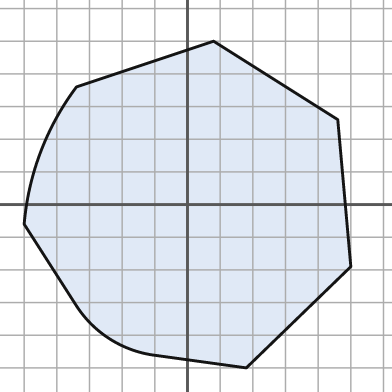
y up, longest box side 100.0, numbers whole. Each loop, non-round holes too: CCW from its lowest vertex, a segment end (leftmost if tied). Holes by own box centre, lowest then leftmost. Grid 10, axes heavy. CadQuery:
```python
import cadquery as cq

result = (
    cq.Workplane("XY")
    .moveTo(18.0, -50.0)
    .lineTo(50.0, -19.0)
    .lineTo(46.0, 26.0)
    .lineTo(8.0, 50.0)
    .lineTo(-34.0, 36.0)
    .threePointArc((-45.0, 16.0), (-50.0, -6.0))
    .lineTo(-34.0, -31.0)
    .threePointArc((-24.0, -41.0), (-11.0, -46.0))
    .close()
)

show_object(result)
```